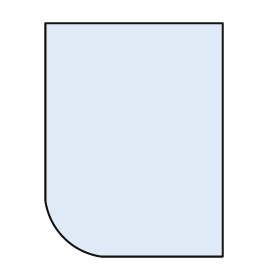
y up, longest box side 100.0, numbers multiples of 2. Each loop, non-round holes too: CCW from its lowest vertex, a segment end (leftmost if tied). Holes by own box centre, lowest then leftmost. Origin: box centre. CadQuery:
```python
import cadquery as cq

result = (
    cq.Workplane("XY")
    .moveTo(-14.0, -50.0)
    .lineTo(38.0, -50.0)
    .lineTo(38.0, 50.0)
    .lineTo(-38.0, 50.0)
    .lineTo(-38.0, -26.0)
    .threePointArc((-30.0, -42.0), (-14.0, -50.0))
    .close()
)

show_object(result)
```